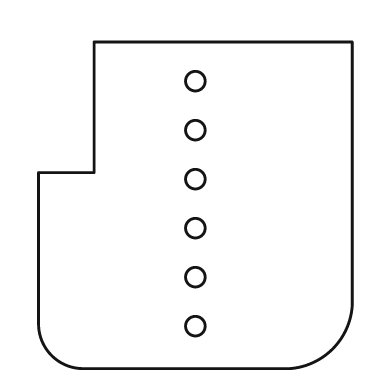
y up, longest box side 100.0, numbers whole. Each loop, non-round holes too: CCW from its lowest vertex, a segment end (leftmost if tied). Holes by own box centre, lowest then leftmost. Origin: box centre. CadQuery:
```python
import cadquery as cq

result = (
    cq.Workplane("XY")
    .moveTo(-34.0, -50.0)
    .lineTo(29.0, -50.0)
    .threePointArc((42.0, -44.0), (48.0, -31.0))
    .lineTo(48.0, 50.0)
    .lineTo(-31.0, 50.0)
    .lineTo(-31.0, 10.0)
    .lineTo(-48.0, 10.0)
    .lineTo(-48.0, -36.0)
    .threePointArc((-44.0, -46.0), (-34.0, -50.0))
    .close()
    .moveTo(0.0, -37.0)
    .circle(3.0)
    .moveTo(0.0, -22.0)
    .circle(3.0)
    .moveTo(0.0, -7.0)
    .circle(3.0)
    .moveTo(0.0, 8.0)
    .circle(3.0)
    .moveTo(0.0, 23.0)
    .circle(3.0)
    .moveTo(0.0, 38.0)
    .circle(3.0)
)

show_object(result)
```